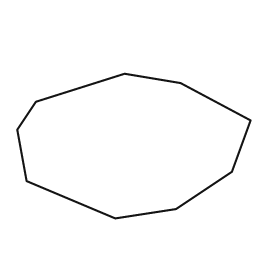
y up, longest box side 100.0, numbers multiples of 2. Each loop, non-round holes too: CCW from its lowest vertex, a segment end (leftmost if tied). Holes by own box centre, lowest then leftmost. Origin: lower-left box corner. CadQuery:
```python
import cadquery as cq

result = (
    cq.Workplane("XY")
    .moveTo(42.0, 0.0)
    .lineTo(68.0, 4.0)
    .lineTo(92.0, 20.0)
    .lineTo(100.0, 42.0)
    .lineTo(70.0, 58.0)
    .lineTo(46.0, 62.0)
    .lineTo(8.0, 50.0)
    .lineTo(0.0, 38.0)
    .lineTo(4.0, 16.0)
    .close()
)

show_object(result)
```